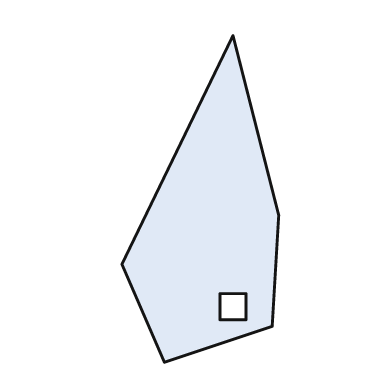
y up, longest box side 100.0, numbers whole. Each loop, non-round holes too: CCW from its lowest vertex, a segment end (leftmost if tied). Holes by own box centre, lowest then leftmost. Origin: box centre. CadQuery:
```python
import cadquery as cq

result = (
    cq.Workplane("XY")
    .moveTo(-11.0, -50.0)
    .lineTo(22.0, -39.0)
    .lineTo(24.0, -5.0)
    .lineTo(10.0, 50.0)
    .lineTo(-24.0, -20.0)
    .close()
    .moveTo(6.0, -37.0)
    .lineTo(14.0, -37.0)
    .lineTo(14.0, -29.0)
    .lineTo(6.0, -29.0)
    .close()
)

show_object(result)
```